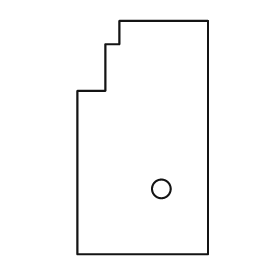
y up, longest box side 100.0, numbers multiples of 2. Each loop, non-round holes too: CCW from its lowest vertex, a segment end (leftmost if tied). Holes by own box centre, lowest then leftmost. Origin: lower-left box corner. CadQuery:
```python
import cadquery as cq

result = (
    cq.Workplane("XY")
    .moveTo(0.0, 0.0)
    .lineTo(56.0, 0.0)
    .lineTo(56.0, 100.0)
    .lineTo(18.0, 100.0)
    .lineTo(18.0, 90.0)
    .lineTo(12.0, 90.0)
    .lineTo(12.0, 70.0)
    .lineTo(0.0, 70.0)
    .close()
    .moveTo(36.0, 28.0)
    .circle(4.0)
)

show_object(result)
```